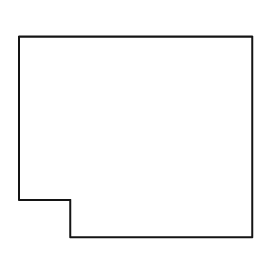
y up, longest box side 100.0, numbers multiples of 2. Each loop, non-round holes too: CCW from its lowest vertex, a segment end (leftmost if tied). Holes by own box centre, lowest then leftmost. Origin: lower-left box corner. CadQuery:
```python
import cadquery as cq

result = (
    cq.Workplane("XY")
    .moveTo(22.0, 0.0)
    .lineTo(100.0, 0.0)
    .lineTo(100.0, 86.0)
    .lineTo(0.0, 86.0)
    .lineTo(0.0, 16.0)
    .lineTo(22.0, 16.0)
    .close()
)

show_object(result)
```